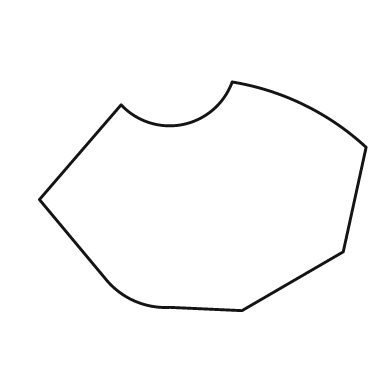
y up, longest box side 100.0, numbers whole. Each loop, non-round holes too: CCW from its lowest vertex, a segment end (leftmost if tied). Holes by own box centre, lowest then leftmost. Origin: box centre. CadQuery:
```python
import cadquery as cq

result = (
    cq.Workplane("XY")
    .moveTo(12.0, -35.0)
    .lineTo(43.0, -17.0)
    .lineTo(50.0, 15.0)
    .threePointArc((31.0, 28.0), (9.0, 35.0))
    .threePointArc((-6.0, 22.0), (-25.0, 28.0))
    .lineTo(-50.0, -1.0)
    .lineTo(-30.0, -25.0)
    .threePointArc((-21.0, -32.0), (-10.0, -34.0))
    .close()
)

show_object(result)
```